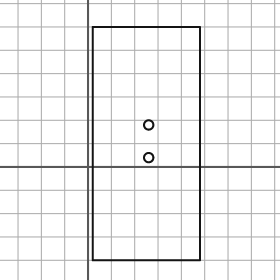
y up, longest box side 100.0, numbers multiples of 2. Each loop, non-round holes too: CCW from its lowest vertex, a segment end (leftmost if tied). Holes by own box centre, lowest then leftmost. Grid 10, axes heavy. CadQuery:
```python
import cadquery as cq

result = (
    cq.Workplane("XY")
    .moveTo(2.0, -40.0)
    .lineTo(48.0, -40.0)
    .lineTo(48.0, 60.0)
    .lineTo(2.0, 60.0)
    .close()
    .moveTo(26.0, 4.0)
    .circle(2.0)
    .moveTo(26.0, 18.0)
    .circle(2.0)
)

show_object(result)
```